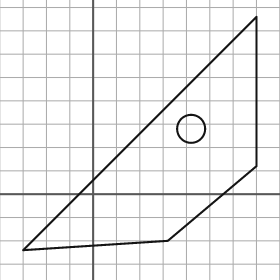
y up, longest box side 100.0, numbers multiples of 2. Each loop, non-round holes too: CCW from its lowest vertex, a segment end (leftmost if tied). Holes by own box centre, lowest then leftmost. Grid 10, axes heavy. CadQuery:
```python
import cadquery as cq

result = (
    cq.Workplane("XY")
    .moveTo(-30.0, -24.0)
    .lineTo(32.0, -20.0)
    .lineTo(70.0, 12.0)
    .lineTo(70.0, 76.0)
    .close()
    .moveTo(42.0, 28.0)
    .circle(6.0)
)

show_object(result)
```